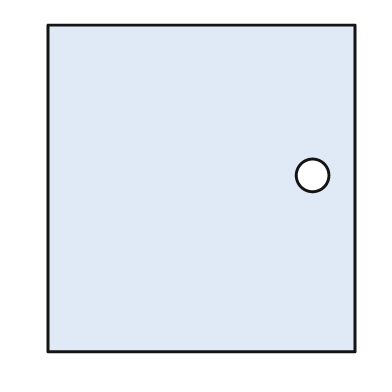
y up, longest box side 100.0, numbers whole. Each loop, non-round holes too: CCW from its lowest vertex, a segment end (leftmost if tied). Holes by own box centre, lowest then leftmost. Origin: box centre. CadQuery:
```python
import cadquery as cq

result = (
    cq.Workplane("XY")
    .moveTo(-47.0, -50.0)
    .lineTo(47.0, -50.0)
    .lineTo(47.0, 50.0)
    .lineTo(-47.0, 50.0)
    .close()
    .moveTo(34.0, 4.0)
    .circle(5.0)
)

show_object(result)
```